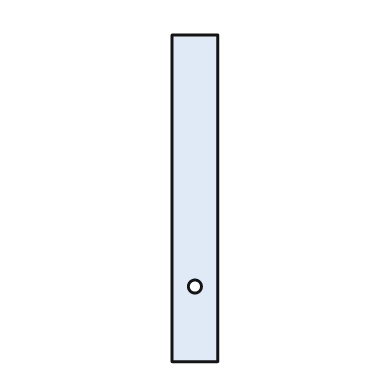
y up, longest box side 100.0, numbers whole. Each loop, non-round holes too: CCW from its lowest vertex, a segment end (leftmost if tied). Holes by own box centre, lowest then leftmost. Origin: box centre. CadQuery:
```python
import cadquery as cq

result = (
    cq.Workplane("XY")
    .moveTo(-7.0, -50.0)
    .lineTo(7.0, -50.0)
    .lineTo(7.0, 50.0)
    .lineTo(-7.0, 50.0)
    .close()
    .moveTo(0.0, -27.0)
    .circle(2.0)
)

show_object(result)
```